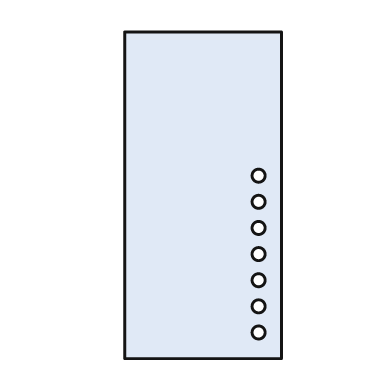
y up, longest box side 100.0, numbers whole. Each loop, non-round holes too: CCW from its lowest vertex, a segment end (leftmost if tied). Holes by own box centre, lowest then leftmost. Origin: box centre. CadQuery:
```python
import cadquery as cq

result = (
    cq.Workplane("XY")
    .moveTo(-24.0, -50.0)
    .lineTo(24.0, -50.0)
    .lineTo(24.0, 50.0)
    .lineTo(-24.0, 50.0)
    .close()
    .moveTo(17.0, -42.0)
    .circle(2.0)
    .moveTo(17.0, -34.0)
    .circle(2.0)
    .moveTo(17.0, -26.0)
    .circle(2.0)
    .moveTo(17.0, -18.0)
    .circle(2.0)
    .moveTo(17.0, -10.0)
    .circle(2.0)
    .moveTo(17.0, -2.0)
    .circle(2.0)
    .moveTo(17.0, 6.0)
    .circle(2.0)
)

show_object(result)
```